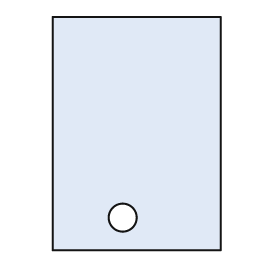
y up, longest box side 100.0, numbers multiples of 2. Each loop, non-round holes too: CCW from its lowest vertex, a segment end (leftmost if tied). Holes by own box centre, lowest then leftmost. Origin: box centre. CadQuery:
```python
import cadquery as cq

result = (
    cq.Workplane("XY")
    .moveTo(-36.0, -50.0)
    .lineTo(36.0, -50.0)
    .lineTo(36.0, 50.0)
    .lineTo(-36.0, 50.0)
    .close()
    .moveTo(-6.0, -36.0)
    .circle(6.0)
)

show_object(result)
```